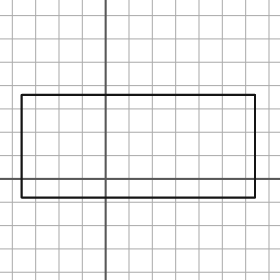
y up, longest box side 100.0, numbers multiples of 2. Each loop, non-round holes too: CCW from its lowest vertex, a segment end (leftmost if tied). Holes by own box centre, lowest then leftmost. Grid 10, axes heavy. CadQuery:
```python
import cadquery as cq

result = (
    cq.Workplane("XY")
    .moveTo(-36.0, -8.0)
    .lineTo(64.0, -8.0)
    .lineTo(64.0, 36.0)
    .lineTo(-36.0, 36.0)
    .close()
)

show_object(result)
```